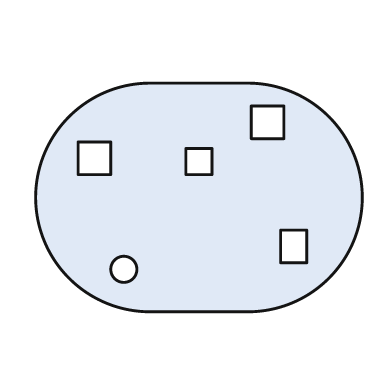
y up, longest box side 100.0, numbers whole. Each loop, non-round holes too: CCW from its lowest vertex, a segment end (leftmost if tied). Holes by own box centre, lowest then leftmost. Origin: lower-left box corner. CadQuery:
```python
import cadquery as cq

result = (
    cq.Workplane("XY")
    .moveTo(35.0, 0.0)
    .lineTo(65.0, 0.0)
    .threePointArc((100.0, 35.0), (65.0, 70.0))
    .lineTo(35.0, 70.0)
    .threePointArc((0.0, 35.0), (35.0, 0.0))
    .close()
    .moveTo(27.0, 13.0)
    .circle(4.0)
    .moveTo(75.0, 15.0)
    .lineTo(83.0, 15.0)
    .lineTo(83.0, 25.0)
    .lineTo(75.0, 25.0)
    .close()
    .moveTo(46.0, 42.0)
    .lineTo(54.0, 42.0)
    .lineTo(54.0, 50.0)
    .lineTo(46.0, 50.0)
    .close()
    .moveTo(13.0, 42.0)
    .lineTo(23.0, 42.0)
    .lineTo(23.0, 52.0)
    .lineTo(13.0, 52.0)
    .close()
    .moveTo(66.0, 53.0)
    .lineTo(76.0, 53.0)
    .lineTo(76.0, 63.0)
    .lineTo(66.0, 63.0)
    .close()
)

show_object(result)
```